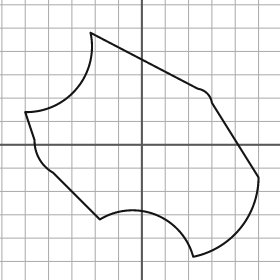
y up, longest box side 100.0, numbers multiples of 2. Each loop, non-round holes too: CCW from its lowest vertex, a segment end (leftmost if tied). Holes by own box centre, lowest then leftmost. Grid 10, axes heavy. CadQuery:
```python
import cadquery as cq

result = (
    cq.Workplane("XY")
    .moveTo(22.0, -48.0)
    .threePointArc((42.0, -36.0), (50.0, -14.0))
    .lineTo(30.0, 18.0)
    .threePointArc((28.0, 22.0), (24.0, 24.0))
    .lineTo(-22.0, 48.0)
    .threePointArc((-28.0, 24.0), (-50.0, 14.0))
    .lineTo(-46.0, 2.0)
    .threePointArc((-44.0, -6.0), (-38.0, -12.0))
    .lineTo(-18.0, -32.0)
    .threePointArc((6.0, -30.0), (22.0, -48.0))
    .close()
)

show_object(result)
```